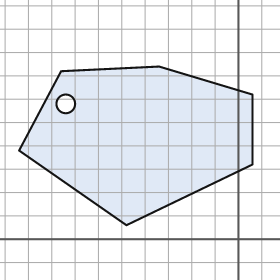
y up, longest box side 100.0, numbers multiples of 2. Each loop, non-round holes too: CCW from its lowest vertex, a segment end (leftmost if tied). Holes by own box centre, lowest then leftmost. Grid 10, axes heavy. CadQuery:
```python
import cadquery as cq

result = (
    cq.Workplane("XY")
    .moveTo(-48.0, 6.0)
    .lineTo(6.0, 32.0)
    .lineTo(6.0, 62.0)
    .lineTo(-34.0, 74.0)
    .lineTo(-76.0, 72.0)
    .lineTo(-94.0, 38.0)
    .close()
    .moveTo(-74.0, 58.0)
    .circle(4.0)
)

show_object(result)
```